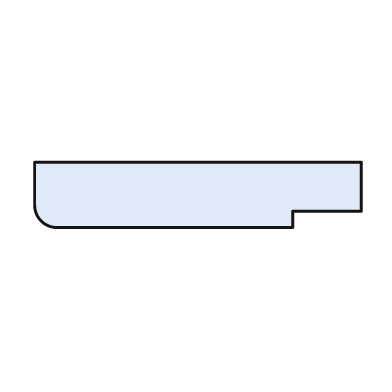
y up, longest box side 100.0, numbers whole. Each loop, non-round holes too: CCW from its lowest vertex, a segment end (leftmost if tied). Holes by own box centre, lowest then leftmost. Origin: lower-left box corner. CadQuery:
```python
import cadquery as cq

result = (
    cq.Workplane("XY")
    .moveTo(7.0, 0.0)
    .lineTo(79.0, 0.0)
    .lineTo(79.0, 5.0)
    .lineTo(100.0, 5.0)
    .lineTo(100.0, 20.0)
    .lineTo(0.0, 20.0)
    .lineTo(0.0, 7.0)
    .threePointArc((2.0, 2.0), (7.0, 0.0))
    .close()
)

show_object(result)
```